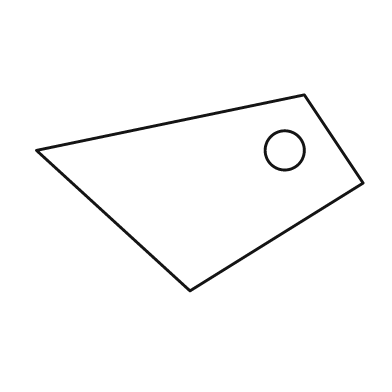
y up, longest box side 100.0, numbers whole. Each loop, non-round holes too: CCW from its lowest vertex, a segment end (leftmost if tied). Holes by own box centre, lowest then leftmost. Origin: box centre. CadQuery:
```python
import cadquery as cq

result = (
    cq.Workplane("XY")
    .moveTo(-3.0, -30.0)
    .lineTo(50.0, 3.0)
    .lineTo(32.0, 30.0)
    .lineTo(-50.0, 13.0)
    .close()
    .moveTo(26.0, 13.0)
    .circle(6.0)
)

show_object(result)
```